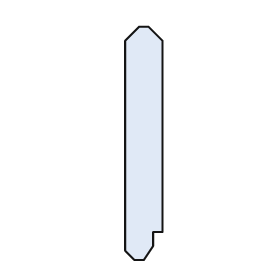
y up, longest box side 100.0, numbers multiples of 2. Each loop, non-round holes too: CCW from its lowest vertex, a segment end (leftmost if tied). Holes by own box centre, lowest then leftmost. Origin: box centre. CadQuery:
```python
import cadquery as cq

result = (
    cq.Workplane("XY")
    .moveTo(-4.0, -50.0)
    .lineTo(0.0, -50.0)
    .lineTo(4.0, -44.0)
    .lineTo(4.0, -38.0)
    .lineTo(8.0, -38.0)
    .lineTo(8.0, 44.0)
    .lineTo(2.0, 50.0)
    .lineTo(-2.0, 50.0)
    .lineTo(-8.0, 44.0)
    .lineTo(-8.0, -46.0)
    .close()
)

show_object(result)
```